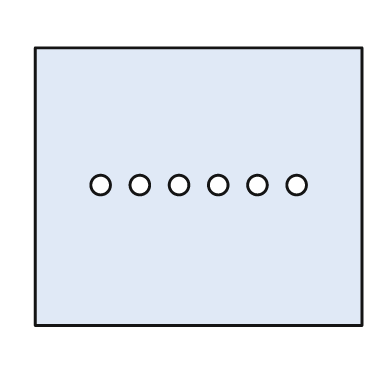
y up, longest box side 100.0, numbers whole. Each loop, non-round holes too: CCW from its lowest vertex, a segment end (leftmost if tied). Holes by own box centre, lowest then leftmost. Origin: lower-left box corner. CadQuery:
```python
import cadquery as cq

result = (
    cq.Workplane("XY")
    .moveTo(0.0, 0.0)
    .lineTo(100.0, 0.0)
    .lineTo(100.0, 85.0)
    .lineTo(0.0, 85.0)
    .close()
    .moveTo(20.0, 43.0)
    .circle(3.0)
    .moveTo(32.0, 43.0)
    .circle(3.0)
    .moveTo(44.0, 43.0)
    .circle(3.0)
    .moveTo(56.0, 43.0)
    .circle(3.0)
    .moveTo(68.0, 43.0)
    .circle(3.0)
    .moveTo(80.0, 43.0)
    .circle(3.0)
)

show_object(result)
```